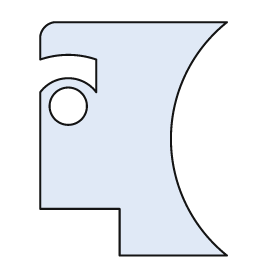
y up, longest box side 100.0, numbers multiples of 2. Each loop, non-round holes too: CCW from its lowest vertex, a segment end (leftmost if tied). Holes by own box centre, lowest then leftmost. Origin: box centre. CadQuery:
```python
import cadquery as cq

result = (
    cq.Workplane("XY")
    .moveTo(-6.0, -50.0)
    .lineTo(40.0, -50.0)
    .threePointArc((16.0, 0.0), (40.0, 50.0))
    .lineTo(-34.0, 50.0)
    .threePointArc((-38.0, 48.0), (-40.0, 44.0))
    .lineTo(-40.0, 34.0)
    .threePointArc((-28.0, 36.0), (-16.0, 34.0))
    .lineTo(-16.0, 20.0)
    .threePointArc((-28.0, 26.0), (-40.0, 20.0))
    .lineTo(-40.0, -30.0)
    .lineTo(-6.0, -30.0)
    .close()
    .moveTo(-28.0, 14.0)
    .circle(8.0)
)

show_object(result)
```